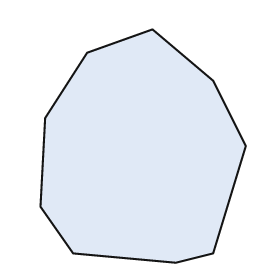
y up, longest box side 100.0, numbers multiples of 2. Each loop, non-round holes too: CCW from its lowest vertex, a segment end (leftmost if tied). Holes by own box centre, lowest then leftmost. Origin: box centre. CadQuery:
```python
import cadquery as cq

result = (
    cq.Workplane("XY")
    .moveTo(14.0, -50.0)
    .lineTo(30.0, -46.0)
    .lineTo(44.0, 0.0)
    .lineTo(30.0, 28.0)
    .lineTo(4.0, 50.0)
    .lineTo(-24.0, 40.0)
    .lineTo(-42.0, 12.0)
    .lineTo(-44.0, -26.0)
    .lineTo(-30.0, -46.0)
    .close()
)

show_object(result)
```